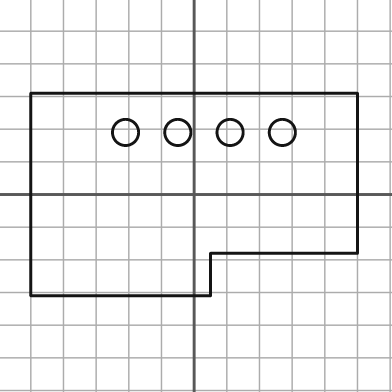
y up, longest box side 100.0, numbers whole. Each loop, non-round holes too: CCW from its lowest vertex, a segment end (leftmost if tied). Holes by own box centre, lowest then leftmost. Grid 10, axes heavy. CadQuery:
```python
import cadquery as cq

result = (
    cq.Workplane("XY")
    .moveTo(-50.0, -31.0)
    .lineTo(5.0, -31.0)
    .lineTo(5.0, -18.0)
    .lineTo(50.0, -18.0)
    .lineTo(50.0, 31.0)
    .lineTo(-50.0, 31.0)
    .close()
    .moveTo(-21.0, 19.0)
    .circle(4.0)
    .moveTo(-5.0, 19.0)
    .circle(4.0)
    .moveTo(11.0, 19.0)
    .circle(4.0)
    .moveTo(27.0, 19.0)
    .circle(4.0)
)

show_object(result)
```